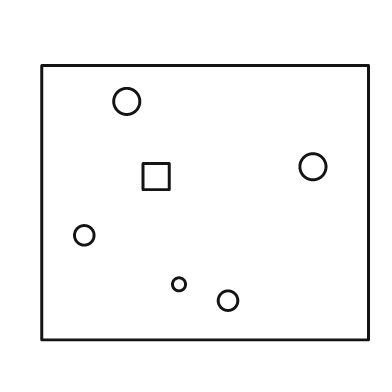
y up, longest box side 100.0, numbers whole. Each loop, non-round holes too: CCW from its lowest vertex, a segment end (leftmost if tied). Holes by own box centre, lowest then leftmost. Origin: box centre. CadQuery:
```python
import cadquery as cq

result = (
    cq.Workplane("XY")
    .moveTo(-50.0, -42.0)
    .lineTo(50.0, -42.0)
    .lineTo(50.0, 42.0)
    .lineTo(-50.0, 42.0)
    .close()
    .moveTo(7.0, -30.0)
    .circle(3.0)
    .moveTo(-8.0, -25.0)
    .circle(2.0)
    .moveTo(-37.0, -10.0)
    .circle(3.0)
    .moveTo(-19.0, 4.0)
    .lineTo(-11.0, 4.0)
    .lineTo(-11.0, 12.0)
    .lineTo(-19.0, 12.0)
    .close()
    .moveTo(33.0, 11.0)
    .circle(4.0)
    .moveTo(-24.0, 31.0)
    .circle(4.0)
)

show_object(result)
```